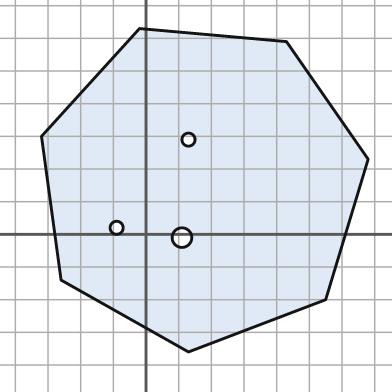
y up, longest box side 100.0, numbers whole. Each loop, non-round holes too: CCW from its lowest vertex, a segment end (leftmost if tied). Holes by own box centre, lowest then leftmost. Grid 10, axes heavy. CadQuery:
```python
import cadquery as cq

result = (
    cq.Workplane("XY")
    .moveTo(13.0, -36.0)
    .lineTo(55.0, -20.0)
    .lineTo(68.0, 23.0)
    .lineTo(43.0, 59.0)
    .lineTo(-2.0, 63.0)
    .lineTo(-32.0, 30.0)
    .lineTo(-26.0, -14.0)
    .close()
    .moveTo(11.0, -1.0)
    .circle(3.0)
    .moveTo(-9.0, 2.0)
    .circle(2.0)
    .moveTo(13.0, 29.0)
    .circle(2.0)
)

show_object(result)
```